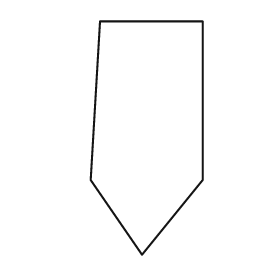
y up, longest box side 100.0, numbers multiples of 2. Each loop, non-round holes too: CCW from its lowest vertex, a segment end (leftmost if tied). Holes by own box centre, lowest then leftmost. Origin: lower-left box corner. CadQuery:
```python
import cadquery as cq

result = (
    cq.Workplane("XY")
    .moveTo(22.0, 0.0)
    .lineTo(48.0, 32.0)
    .lineTo(48.0, 100.0)
    .lineTo(4.0, 100.0)
    .lineTo(0.0, 32.0)
    .close()
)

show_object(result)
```